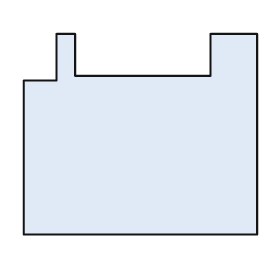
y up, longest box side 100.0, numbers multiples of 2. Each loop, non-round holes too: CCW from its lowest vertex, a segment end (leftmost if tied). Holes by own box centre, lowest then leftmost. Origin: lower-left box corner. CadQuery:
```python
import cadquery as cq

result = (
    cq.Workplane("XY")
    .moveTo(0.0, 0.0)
    .lineTo(100.0, 0.0)
    .lineTo(100.0, 86.0)
    .lineTo(80.0, 86.0)
    .lineTo(80.0, 68.0)
    .lineTo(22.0, 68.0)
    .lineTo(22.0, 86.0)
    .lineTo(14.0, 86.0)
    .lineTo(14.0, 66.0)
    .lineTo(0.0, 66.0)
    .close()
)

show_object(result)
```